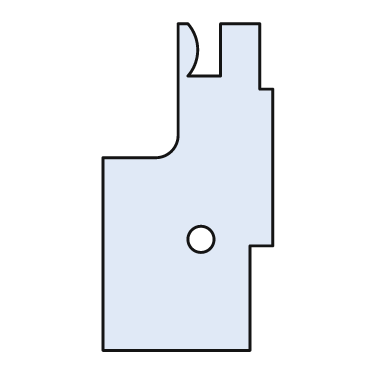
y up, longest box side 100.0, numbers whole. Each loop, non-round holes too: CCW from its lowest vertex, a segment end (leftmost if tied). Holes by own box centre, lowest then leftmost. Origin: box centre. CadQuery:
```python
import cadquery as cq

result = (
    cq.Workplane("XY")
    .moveTo(-26.0, -50.0)
    .lineTo(19.0, -50.0)
    .lineTo(19.0, -18.0)
    .lineTo(26.0, -18.0)
    .lineTo(26.0, 30.0)
    .lineTo(22.0, 30.0)
    .lineTo(22.0, 50.0)
    .lineTo(10.0, 50.0)
    .lineTo(10.0, 34.0)
    .lineTo(0.0, 34.0)
    .threePointArc((3.0, 42.0), (0.0, 50.0))
    .lineTo(-3.0, 50.0)
    .lineTo(-3.0, 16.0)
    .threePointArc((-5.0, 11.0), (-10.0, 9.0))
    .lineTo(-26.0, 9.0)
    .close()
    .moveTo(4.0, -16.0)
    .circle(4.0)
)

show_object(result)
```